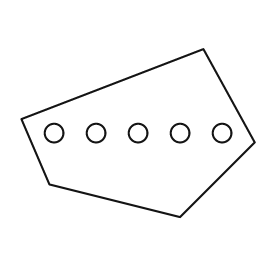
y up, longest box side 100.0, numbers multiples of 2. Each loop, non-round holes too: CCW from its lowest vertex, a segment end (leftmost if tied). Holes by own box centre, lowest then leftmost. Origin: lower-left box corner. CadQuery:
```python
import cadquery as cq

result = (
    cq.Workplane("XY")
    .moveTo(68.0, 0.0)
    .lineTo(100.0, 32.0)
    .lineTo(78.0, 72.0)
    .lineTo(0.0, 42.0)
    .lineTo(12.0, 14.0)
    .close()
    .moveTo(14.0, 36.0)
    .circle(4.0)
    .moveTo(32.0, 36.0)
    .circle(4.0)
    .moveTo(50.0, 36.0)
    .circle(4.0)
    .moveTo(68.0, 36.0)
    .circle(4.0)
    .moveTo(86.0, 36.0)
    .circle(4.0)
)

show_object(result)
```